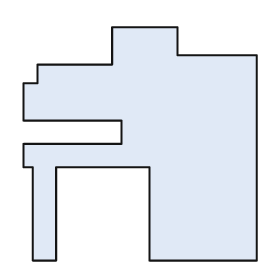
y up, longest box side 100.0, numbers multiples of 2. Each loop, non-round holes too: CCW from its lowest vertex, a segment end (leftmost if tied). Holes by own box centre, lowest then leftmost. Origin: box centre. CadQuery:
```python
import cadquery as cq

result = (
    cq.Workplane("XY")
    .moveTo(-46.0, -50.0)
    .lineTo(-36.0, -50.0)
    .lineTo(-36.0, -10.0)
    .lineTo(4.0, -10.0)
    .lineTo(4.0, -50.0)
    .lineTo(50.0, -50.0)
    .lineTo(50.0, 38.0)
    .lineTo(16.0, 38.0)
    .lineTo(16.0, 50.0)
    .lineTo(-12.0, 50.0)
    .lineTo(-12.0, 34.0)
    .lineTo(-44.0, 34.0)
    .lineTo(-44.0, 26.0)
    .lineTo(-50.0, 26.0)
    .lineTo(-50.0, 10.0)
    .lineTo(-8.0, 10.0)
    .lineTo(-8.0, 0.0)
    .lineTo(-50.0, 0.0)
    .lineTo(-50.0, -10.0)
    .lineTo(-46.0, -10.0)
    .close()
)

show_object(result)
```